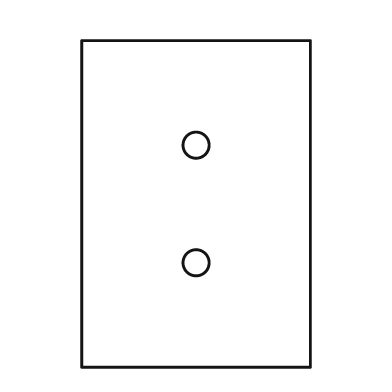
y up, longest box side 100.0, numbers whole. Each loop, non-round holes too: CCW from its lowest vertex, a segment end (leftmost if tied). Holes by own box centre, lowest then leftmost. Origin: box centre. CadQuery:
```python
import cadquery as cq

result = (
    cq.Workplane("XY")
    .moveTo(-35.0, -50.0)
    .lineTo(35.0, -50.0)
    .lineTo(35.0, 50.0)
    .lineTo(-35.0, 50.0)
    .close()
    .moveTo(0.0, -18.0)
    .circle(4.0)
    .moveTo(0.0, 18.0)
    .circle(4.0)
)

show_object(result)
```